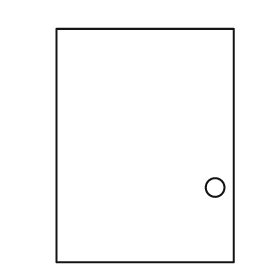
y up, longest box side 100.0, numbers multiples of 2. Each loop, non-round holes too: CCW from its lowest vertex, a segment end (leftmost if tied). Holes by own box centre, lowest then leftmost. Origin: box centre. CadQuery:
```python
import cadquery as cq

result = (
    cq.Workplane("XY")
    .moveTo(-38.0, -50.0)
    .lineTo(38.0, -50.0)
    .lineTo(38.0, 50.0)
    .lineTo(-38.0, 50.0)
    .close()
    .moveTo(30.0, -18.0)
    .circle(4.0)
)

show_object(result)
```